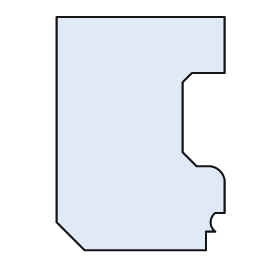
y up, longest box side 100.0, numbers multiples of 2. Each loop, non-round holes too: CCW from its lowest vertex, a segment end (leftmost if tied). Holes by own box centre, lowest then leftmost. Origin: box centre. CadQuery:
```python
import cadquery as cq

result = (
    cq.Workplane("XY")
    .moveTo(-24.0, -50.0)
    .lineTo(28.0, -50.0)
    .lineTo(28.0, -42.0)
    .lineTo(32.0, -42.0)
    .threePointArc((30.0, -38.0), (32.0, -34.0))
    .lineTo(36.0, -34.0)
    .lineTo(36.0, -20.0)
    .threePointArc((34.0, -16.0), (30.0, -14.0))
    .lineTo(24.0, -14.0)
    .lineTo(18.0, -8.0)
    .lineTo(18.0, 22.0)
    .lineTo(22.0, 26.0)
    .lineTo(36.0, 26.0)
    .lineTo(36.0, 50.0)
    .lineTo(-36.0, 50.0)
    .lineTo(-36.0, -38.0)
    .close()
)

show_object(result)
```